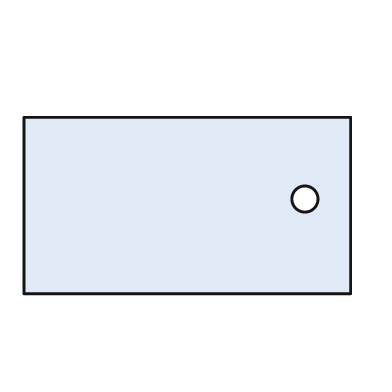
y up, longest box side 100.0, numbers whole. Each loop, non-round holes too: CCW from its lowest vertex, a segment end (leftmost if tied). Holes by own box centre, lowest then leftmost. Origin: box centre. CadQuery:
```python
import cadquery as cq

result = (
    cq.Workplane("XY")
    .moveTo(-50.0, -27.0)
    .lineTo(50.0, -27.0)
    .lineTo(50.0, 27.0)
    .lineTo(-50.0, 27.0)
    .close()
    .moveTo(36.0, 2.0)
    .circle(4.0)
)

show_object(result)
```